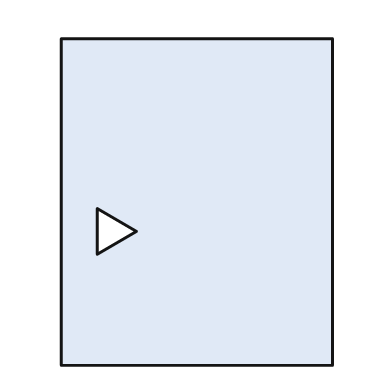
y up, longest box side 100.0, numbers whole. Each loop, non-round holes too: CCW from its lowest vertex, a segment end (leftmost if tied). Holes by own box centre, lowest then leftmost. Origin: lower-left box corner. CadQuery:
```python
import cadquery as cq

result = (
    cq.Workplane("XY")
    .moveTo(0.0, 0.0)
    .lineTo(83.0, 0.0)
    .lineTo(83.0, 100.0)
    .lineTo(0.0, 100.0)
    .close()
    .moveTo(11.0, 34.0)
    .lineTo(23.0, 41.0)
    .lineTo(11.0, 48.0)
    .close()
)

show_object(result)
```